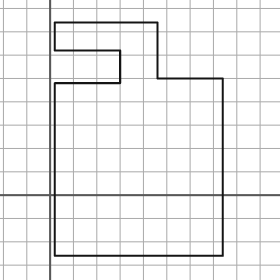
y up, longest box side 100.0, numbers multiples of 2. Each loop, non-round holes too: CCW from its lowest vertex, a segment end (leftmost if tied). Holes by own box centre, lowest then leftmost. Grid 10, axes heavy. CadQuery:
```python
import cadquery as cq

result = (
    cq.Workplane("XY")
    .moveTo(2.0, -26.0)
    .lineTo(74.0, -26.0)
    .lineTo(74.0, 50.0)
    .lineTo(46.0, 50.0)
    .lineTo(46.0, 74.0)
    .lineTo(2.0, 74.0)
    .lineTo(2.0, 62.0)
    .lineTo(30.0, 62.0)
    .lineTo(30.0, 48.0)
    .lineTo(2.0, 48.0)
    .close()
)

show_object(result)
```